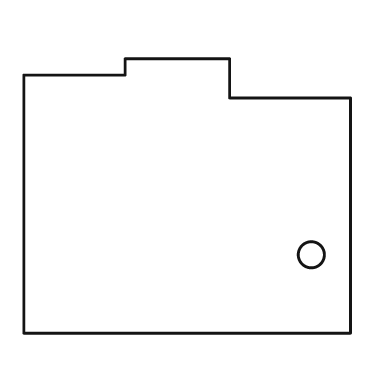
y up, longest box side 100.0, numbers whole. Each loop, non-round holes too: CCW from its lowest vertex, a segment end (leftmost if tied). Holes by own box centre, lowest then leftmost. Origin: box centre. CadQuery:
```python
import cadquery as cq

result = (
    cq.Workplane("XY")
    .moveTo(-50.0, -42.0)
    .lineTo(50.0, -42.0)
    .lineTo(50.0, 30.0)
    .lineTo(13.0, 30.0)
    .lineTo(13.0, 42.0)
    .lineTo(-19.0, 42.0)
    .lineTo(-19.0, 37.0)
    .lineTo(-50.0, 37.0)
    .close()
    .moveTo(38.0, -18.0)
    .circle(4.0)
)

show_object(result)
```